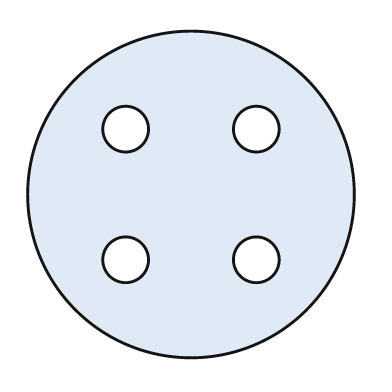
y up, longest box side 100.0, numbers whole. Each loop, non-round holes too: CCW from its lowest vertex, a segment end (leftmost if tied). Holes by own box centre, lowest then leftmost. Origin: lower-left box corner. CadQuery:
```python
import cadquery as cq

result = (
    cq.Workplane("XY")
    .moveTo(50.0, 50.0)
    .circle(50.0)
    .moveTo(30.0, 30.0)
    .circle(7.0)
    .moveTo(70.0, 30.0)
    .circle(7.0)
    .moveTo(30.0, 70.0)
    .circle(7.0)
    .moveTo(70.0, 70.0)
    .circle(7.0)
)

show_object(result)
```